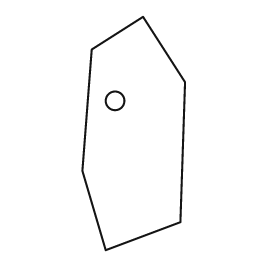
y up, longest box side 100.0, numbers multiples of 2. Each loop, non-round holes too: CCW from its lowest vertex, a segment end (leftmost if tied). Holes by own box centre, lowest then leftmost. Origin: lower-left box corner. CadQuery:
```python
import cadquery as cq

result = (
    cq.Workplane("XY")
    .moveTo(10.0, 0.0)
    .lineTo(42.0, 12.0)
    .lineTo(44.0, 72.0)
    .lineTo(26.0, 100.0)
    .lineTo(4.0, 86.0)
    .lineTo(0.0, 34.0)
    .close()
    .moveTo(14.0, 64.0)
    .circle(4.0)
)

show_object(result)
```